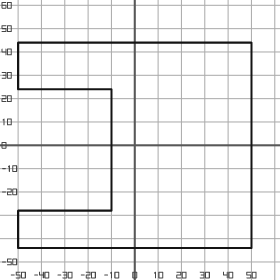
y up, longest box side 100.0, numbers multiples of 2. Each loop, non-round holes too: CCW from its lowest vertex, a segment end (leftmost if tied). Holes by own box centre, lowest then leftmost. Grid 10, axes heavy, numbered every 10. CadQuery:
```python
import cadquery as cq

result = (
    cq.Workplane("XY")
    .moveTo(-50.0, -44.0)
    .lineTo(50.0, -44.0)
    .lineTo(50.0, 44.0)
    .lineTo(-50.0, 44.0)
    .lineTo(-50.0, 24.0)
    .lineTo(-10.0, 24.0)
    .lineTo(-10.0, -28.0)
    .lineTo(-50.0, -28.0)
    .close()
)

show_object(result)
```